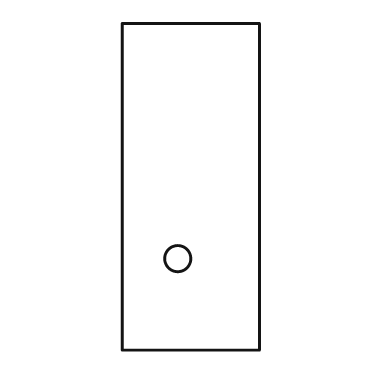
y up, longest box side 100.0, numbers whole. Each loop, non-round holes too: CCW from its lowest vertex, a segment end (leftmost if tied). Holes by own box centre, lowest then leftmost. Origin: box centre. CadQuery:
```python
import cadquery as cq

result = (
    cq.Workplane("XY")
    .moveTo(-21.0, -50.0)
    .lineTo(21.0, -50.0)
    .lineTo(21.0, 50.0)
    .lineTo(-21.0, 50.0)
    .close()
    .moveTo(-4.0, -22.0)
    .circle(4.0)
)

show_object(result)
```